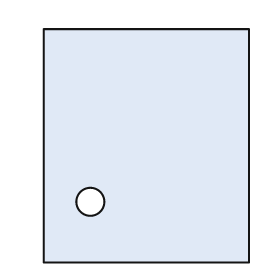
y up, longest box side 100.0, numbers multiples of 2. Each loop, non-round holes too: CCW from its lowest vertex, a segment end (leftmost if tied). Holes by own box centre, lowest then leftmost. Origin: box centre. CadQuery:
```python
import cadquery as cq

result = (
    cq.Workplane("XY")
    .moveTo(-44.0, -50.0)
    .lineTo(44.0, -50.0)
    .lineTo(44.0, 50.0)
    .lineTo(-44.0, 50.0)
    .close()
    .moveTo(-24.0, -24.0)
    .circle(6.0)
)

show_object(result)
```